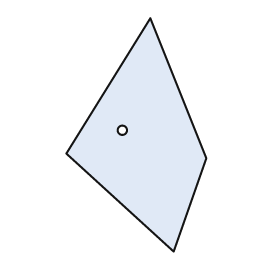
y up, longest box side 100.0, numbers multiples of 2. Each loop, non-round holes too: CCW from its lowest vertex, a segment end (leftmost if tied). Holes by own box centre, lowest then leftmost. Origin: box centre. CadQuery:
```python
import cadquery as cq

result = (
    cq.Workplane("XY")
    .moveTo(16.0, -50.0)
    .lineTo(30.0, -10.0)
    .lineTo(6.0, 50.0)
    .lineTo(-30.0, -8.0)
    .close()
    .moveTo(-6.0, 2.0)
    .circle(2.0)
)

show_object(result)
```